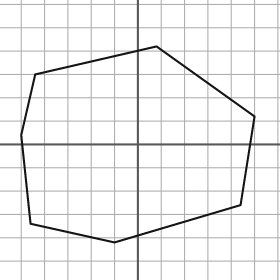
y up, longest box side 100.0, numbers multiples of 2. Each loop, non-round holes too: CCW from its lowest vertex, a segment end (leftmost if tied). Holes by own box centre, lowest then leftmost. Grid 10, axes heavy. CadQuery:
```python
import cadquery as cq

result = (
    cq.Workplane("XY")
    .moveTo(-10.0, -42.0)
    .lineTo(44.0, -26.0)
    .lineTo(50.0, 12.0)
    .lineTo(8.0, 42.0)
    .lineTo(-44.0, 30.0)
    .lineTo(-50.0, 4.0)
    .lineTo(-46.0, -34.0)
    .close()
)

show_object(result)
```